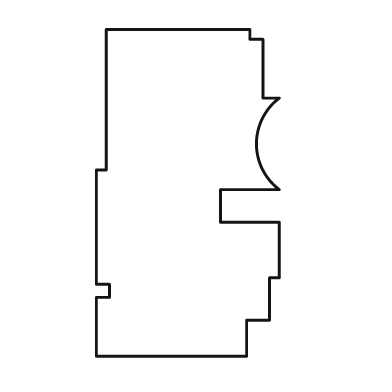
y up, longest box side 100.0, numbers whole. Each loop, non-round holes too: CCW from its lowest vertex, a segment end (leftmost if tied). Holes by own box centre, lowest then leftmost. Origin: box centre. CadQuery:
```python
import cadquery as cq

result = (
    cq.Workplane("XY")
    .moveTo(-28.0, -50.0)
    .lineTo(18.0, -50.0)
    .lineTo(18.0, -39.0)
    .lineTo(25.0, -39.0)
    .lineTo(25.0, -26.0)
    .lineTo(28.0, -26.0)
    .lineTo(28.0, -9.0)
    .lineTo(10.0, -9.0)
    .lineTo(10.0, 1.0)
    .lineTo(28.0, 1.0)
    .threePointArc((21.0, 15.0), (28.0, 29.0))
    .lineTo(23.0, 29.0)
    .lineTo(23.0, 47.0)
    .lineTo(19.0, 47.0)
    .lineTo(19.0, 50.0)
    .lineTo(-25.0, 50.0)
    .lineTo(-25.0, 7.0)
    .lineTo(-28.0, 7.0)
    .lineTo(-28.0, -28.0)
    .lineTo(-24.0, -28.0)
    .lineTo(-24.0, -32.0)
    .lineTo(-28.0, -32.0)
    .close()
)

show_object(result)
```